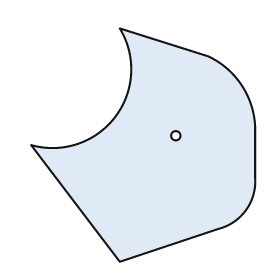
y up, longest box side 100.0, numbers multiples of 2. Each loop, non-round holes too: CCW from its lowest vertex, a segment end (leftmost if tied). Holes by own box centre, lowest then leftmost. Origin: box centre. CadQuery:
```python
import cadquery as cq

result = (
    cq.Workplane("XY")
    .moveTo(-10.0, -50.0)
    .lineTo(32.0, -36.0)
    .threePointArc((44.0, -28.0), (48.0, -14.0))
    .lineTo(48.0, 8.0)
    .threePointArc((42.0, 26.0), (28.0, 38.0))
    .lineTo(-10.0, 50.0)
    .threePointArc((-12.0, 12.0), (-48.0, 0.0))
    .close()
    .moveTo(14.0, 4.0)
    .circle(2.0)
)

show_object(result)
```